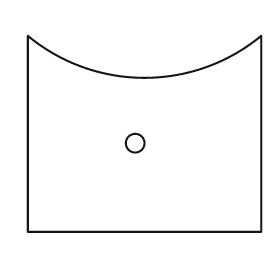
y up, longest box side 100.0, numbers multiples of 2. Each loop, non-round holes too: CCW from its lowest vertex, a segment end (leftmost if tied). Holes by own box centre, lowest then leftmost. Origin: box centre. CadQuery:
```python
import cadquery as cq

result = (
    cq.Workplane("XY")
    .moveTo(-50.0, -42.0)
    .lineTo(50.0, -42.0)
    .lineTo(50.0, 42.0)
    .threePointArc((0.0, 24.0), (-50.0, 42.0))
    .close()
    .moveTo(-4.0, -4.0)
    .circle(4.0)
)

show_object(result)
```